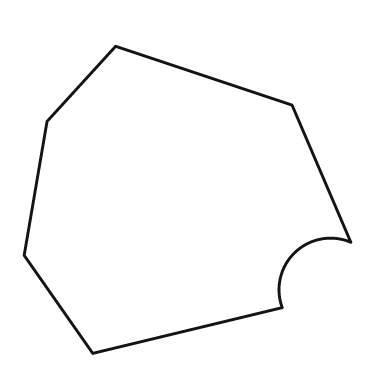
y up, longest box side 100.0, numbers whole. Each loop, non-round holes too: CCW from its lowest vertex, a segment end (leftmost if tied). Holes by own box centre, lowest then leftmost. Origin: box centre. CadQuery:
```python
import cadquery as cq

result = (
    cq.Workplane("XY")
    .moveTo(-29.0, -47.0)
    .lineTo(29.0, -33.0)
    .threePointArc((33.0, -16.0), (50.0, -13.0))
    .lineTo(32.0, 29.0)
    .lineTo(-22.0, 47.0)
    .lineTo(-43.0, 24.0)
    .lineTo(-50.0, -17.0)
    .close()
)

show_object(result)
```